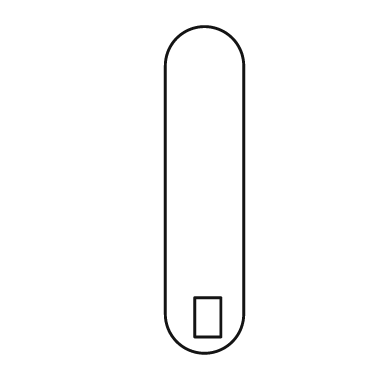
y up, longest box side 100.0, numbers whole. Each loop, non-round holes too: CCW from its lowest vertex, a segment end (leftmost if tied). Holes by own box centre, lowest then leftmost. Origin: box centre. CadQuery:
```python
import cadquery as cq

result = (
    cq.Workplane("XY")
    .moveTo(-12.0, -38.0)
    .threePointArc((0.0, -50.0), (12.0, -38.0))
    .lineTo(12.0, 38.0)
    .threePointArc((0.0, 50.0), (-12.0, 38.0))
    .close()
    .moveTo(-3.0, -45.0)
    .lineTo(5.0, -45.0)
    .lineTo(5.0, -33.0)
    .lineTo(-3.0, -33.0)
    .close()
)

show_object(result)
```